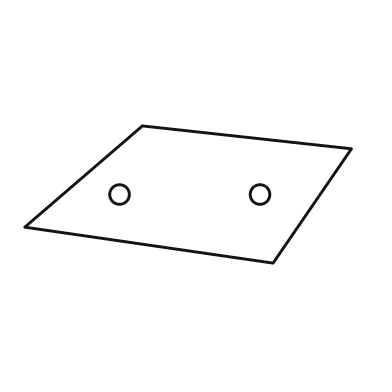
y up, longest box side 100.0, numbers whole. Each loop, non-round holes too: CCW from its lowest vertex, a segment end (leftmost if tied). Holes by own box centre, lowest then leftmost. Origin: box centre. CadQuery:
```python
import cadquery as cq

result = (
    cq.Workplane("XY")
    .moveTo(26.0, -21.0)
    .lineTo(50.0, 14.0)
    .lineTo(-14.0, 21.0)
    .lineTo(-50.0, -10.0)
    .close()
    .moveTo(-21.0, 0.0)
    .circle(3.0)
    .moveTo(22.0, 0.0)
    .circle(3.0)
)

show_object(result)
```